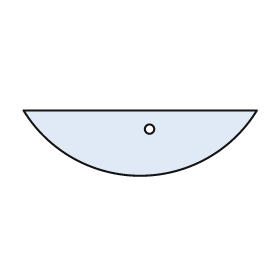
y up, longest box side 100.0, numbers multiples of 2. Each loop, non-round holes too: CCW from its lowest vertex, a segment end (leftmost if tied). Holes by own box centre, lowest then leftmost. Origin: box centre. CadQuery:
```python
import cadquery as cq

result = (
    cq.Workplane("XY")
    .moveTo(-50.0, 14.0)
    .threePointArc((0.0, -14.0), (50.0, 14.0))
    .close()
    .moveTo(4.0, 6.0)
    .circle(2.0)
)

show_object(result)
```